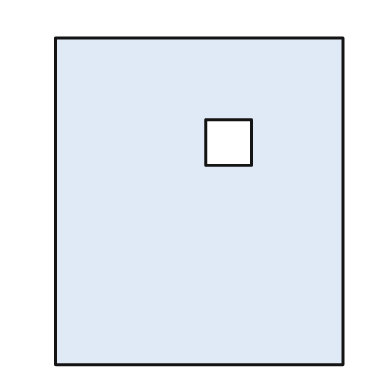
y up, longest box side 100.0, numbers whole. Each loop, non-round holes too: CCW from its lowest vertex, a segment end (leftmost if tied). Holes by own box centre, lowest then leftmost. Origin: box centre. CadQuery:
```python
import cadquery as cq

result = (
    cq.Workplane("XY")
    .moveTo(-44.0, -50.0)
    .lineTo(44.0, -50.0)
    .lineTo(44.0, 50.0)
    .lineTo(-44.0, 50.0)
    .close()
    .moveTo(2.0, 11.0)
    .lineTo(16.0, 11.0)
    .lineTo(16.0, 25.0)
    .lineTo(2.0, 25.0)
    .close()
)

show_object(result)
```